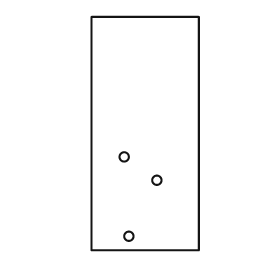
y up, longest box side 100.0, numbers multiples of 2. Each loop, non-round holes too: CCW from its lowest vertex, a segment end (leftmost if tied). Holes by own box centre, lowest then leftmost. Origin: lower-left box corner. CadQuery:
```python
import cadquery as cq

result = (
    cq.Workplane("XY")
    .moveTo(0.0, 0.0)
    .lineTo(46.0, 0.0)
    .lineTo(46.0, 100.0)
    .lineTo(0.0, 100.0)
    .close()
    .moveTo(16.0, 6.0)
    .circle(2.0)
    .moveTo(28.0, 30.0)
    .circle(2.0)
    .moveTo(14.0, 40.0)
    .circle(2.0)
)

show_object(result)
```